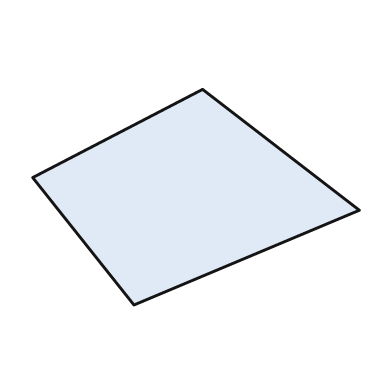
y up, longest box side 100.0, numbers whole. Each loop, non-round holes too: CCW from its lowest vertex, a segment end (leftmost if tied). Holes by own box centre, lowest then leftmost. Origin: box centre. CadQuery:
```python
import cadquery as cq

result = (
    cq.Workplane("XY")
    .moveTo(-19.0, -33.0)
    .lineTo(50.0, -4.0)
    .lineTo(2.0, 33.0)
    .lineTo(-50.0, 6.0)
    .close()
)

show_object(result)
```